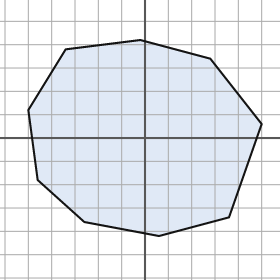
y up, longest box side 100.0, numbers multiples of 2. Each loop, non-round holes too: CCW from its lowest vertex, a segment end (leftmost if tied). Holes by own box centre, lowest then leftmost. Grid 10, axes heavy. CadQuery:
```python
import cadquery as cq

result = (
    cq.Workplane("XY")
    .moveTo(6.0, -42.0)
    .lineTo(36.0, -34.0)
    .lineTo(50.0, 6.0)
    .lineTo(28.0, 34.0)
    .lineTo(-2.0, 42.0)
    .lineTo(-34.0, 38.0)
    .lineTo(-50.0, 12.0)
    .lineTo(-46.0, -18.0)
    .lineTo(-26.0, -36.0)
    .close()
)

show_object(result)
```